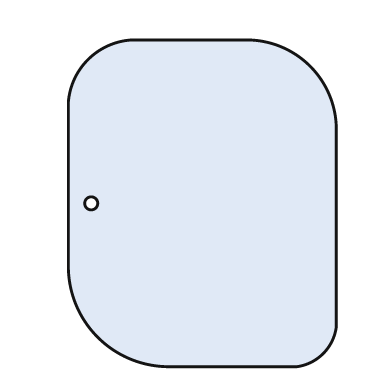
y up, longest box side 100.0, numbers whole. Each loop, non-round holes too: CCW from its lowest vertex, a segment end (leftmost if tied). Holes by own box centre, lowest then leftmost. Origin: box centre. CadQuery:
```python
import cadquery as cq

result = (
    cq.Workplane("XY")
    .moveTo(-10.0, -50.0)
    .lineTo(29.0, -50.0)
    .threePointArc((37.0, -46.0), (41.0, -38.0))
    .lineTo(41.0, 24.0)
    .threePointArc((33.0, 42.0), (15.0, 50.0))
    .lineTo(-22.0, 50.0)
    .threePointArc((-35.0, 44.0), (-41.0, 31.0))
    .lineTo(-41.0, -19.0)
    .threePointArc((-32.0, -41.0), (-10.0, -50.0))
    .close()
    .moveTo(-34.0, 0.0)
    .circle(2.0)
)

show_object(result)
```